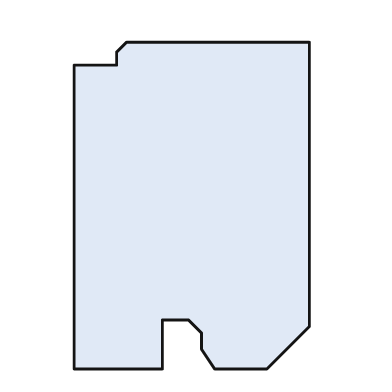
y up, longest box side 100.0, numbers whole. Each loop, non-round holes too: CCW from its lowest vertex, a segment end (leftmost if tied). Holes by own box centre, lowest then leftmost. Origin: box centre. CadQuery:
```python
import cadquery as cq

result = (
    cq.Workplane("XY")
    .moveTo(-36.0, -50.0)
    .lineTo(-9.0, -50.0)
    .lineTo(-9.0, -35.0)
    .lineTo(-1.0, -35.0)
    .lineTo(3.0, -39.0)
    .lineTo(3.0, -44.0)
    .lineTo(7.0, -50.0)
    .lineTo(23.0, -50.0)
    .lineTo(36.0, -37.0)
    .lineTo(36.0, 50.0)
    .lineTo(-20.0, 50.0)
    .lineTo(-23.0, 47.0)
    .lineTo(-23.0, 43.0)
    .lineTo(-36.0, 43.0)
    .close()
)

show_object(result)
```